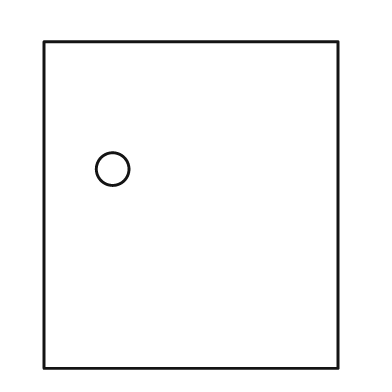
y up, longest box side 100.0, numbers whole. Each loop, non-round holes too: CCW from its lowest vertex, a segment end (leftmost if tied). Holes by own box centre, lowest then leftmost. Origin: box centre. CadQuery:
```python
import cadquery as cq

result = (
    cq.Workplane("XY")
    .moveTo(-45.0, -50.0)
    .lineTo(45.0, -50.0)
    .lineTo(45.0, 50.0)
    .lineTo(-45.0, 50.0)
    .close()
    .moveTo(-24.0, 11.0)
    .circle(5.0)
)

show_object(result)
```